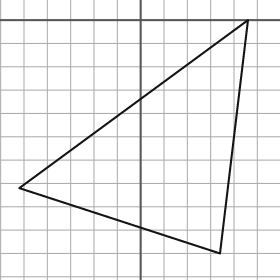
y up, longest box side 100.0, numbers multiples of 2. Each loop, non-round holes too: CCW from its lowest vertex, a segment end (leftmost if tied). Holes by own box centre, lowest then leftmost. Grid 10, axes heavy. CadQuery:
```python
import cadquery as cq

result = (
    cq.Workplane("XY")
    .moveTo(34.0, -100.0)
    .lineTo(46.0, 0.0)
    .lineTo(-52.0, -72.0)
    .close()
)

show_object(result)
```